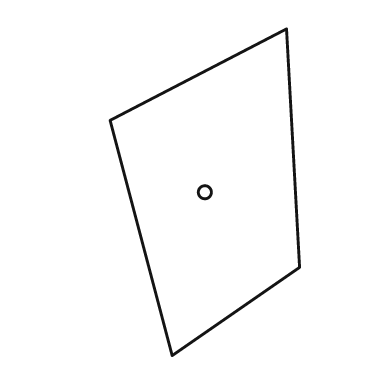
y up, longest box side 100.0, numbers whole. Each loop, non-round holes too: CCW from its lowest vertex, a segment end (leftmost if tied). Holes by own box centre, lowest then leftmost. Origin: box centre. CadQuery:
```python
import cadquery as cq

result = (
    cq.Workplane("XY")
    .moveTo(-10.0, -50.0)
    .lineTo(29.0, -23.0)
    .lineTo(25.0, 50.0)
    .lineTo(-29.0, 22.0)
    .close()
    .moveTo(0.0, 0.0)
    .circle(2.0)
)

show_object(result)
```